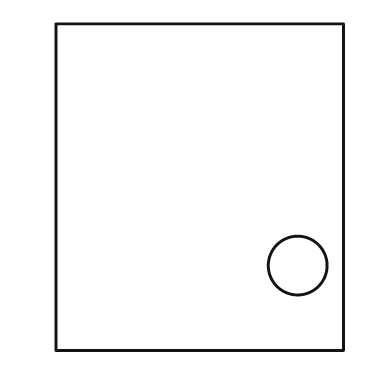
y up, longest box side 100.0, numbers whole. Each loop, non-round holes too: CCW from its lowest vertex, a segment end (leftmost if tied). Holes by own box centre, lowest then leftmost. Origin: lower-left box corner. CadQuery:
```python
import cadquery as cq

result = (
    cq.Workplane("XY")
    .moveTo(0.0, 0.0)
    .lineTo(88.0, 0.0)
    .lineTo(88.0, 100.0)
    .lineTo(0.0, 100.0)
    .close()
    .moveTo(74.0, 26.0)
    .circle(9.0)
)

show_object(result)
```